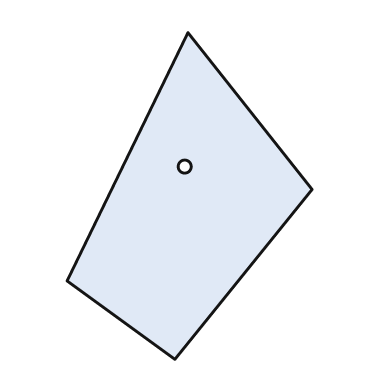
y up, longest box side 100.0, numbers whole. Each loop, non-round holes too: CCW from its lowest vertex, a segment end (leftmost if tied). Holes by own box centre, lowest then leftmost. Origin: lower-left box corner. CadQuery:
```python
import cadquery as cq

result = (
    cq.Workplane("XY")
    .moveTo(33.0, 0.0)
    .lineTo(75.0, 52.0)
    .lineTo(37.0, 100.0)
    .lineTo(0.0, 24.0)
    .close()
    .moveTo(36.0, 59.0)
    .circle(2.0)
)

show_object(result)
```